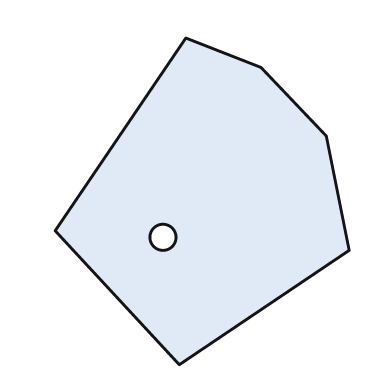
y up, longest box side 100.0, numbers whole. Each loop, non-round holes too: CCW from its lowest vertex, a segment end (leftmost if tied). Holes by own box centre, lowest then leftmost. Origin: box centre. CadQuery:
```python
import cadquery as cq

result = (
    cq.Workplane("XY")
    .moveTo(-7.0, -50.0)
    .lineTo(45.0, -15.0)
    .lineTo(38.0, 20.0)
    .lineTo(18.0, 41.0)
    .lineTo(-5.0, 50.0)
    .lineTo(-45.0, -9.0)
    .close()
    .moveTo(-12.0, -11.0)
    .circle(4.0)
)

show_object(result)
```